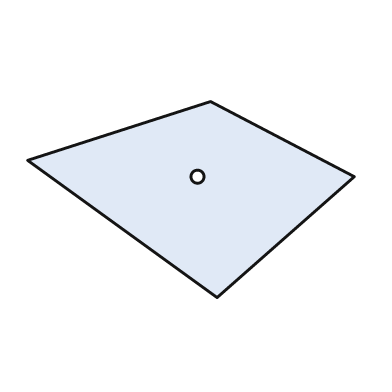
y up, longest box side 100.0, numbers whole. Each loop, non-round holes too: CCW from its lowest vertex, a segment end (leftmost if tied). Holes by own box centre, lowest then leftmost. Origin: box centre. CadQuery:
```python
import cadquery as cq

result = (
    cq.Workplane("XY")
    .moveTo(8.0, -30.0)
    .lineTo(50.0, 7.0)
    .lineTo(6.0, 30.0)
    .lineTo(-50.0, 12.0)
    .close()
    .moveTo(2.0, 7.0)
    .circle(2.0)
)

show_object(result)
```